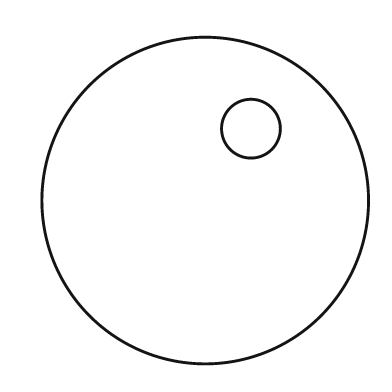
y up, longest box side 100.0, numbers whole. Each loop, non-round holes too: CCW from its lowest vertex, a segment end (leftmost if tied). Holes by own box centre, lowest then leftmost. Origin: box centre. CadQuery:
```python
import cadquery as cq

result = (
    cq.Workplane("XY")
    .moveTo(0.0, 0.0)
    .circle(50.0)
    .moveTo(14.0, 22.0)
    .circle(9.0)
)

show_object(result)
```